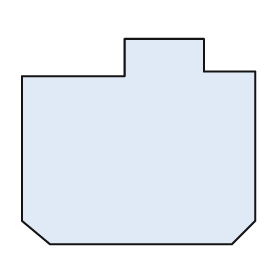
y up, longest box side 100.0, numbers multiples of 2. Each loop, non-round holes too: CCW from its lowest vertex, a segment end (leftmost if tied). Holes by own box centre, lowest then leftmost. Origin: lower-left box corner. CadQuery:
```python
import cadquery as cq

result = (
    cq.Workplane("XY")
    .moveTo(12.0, 0.0)
    .lineTo(90.0, 0.0)
    .lineTo(100.0, 10.0)
    .lineTo(100.0, 74.0)
    .lineTo(78.0, 74.0)
    .lineTo(78.0, 88.0)
    .lineTo(44.0, 88.0)
    .lineTo(44.0, 72.0)
    .lineTo(0.0, 72.0)
    .lineTo(0.0, 10.0)
    .close()
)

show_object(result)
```